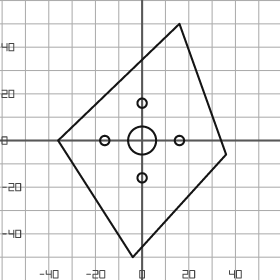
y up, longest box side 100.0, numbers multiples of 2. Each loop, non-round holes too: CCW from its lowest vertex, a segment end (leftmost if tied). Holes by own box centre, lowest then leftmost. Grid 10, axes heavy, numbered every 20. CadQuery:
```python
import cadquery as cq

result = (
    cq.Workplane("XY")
    .moveTo(-4.0, -50.0)
    .lineTo(36.0, -6.0)
    .lineTo(16.0, 50.0)
    .lineTo(-36.0, 0.0)
    .close()
    .moveTo(0.0, -16.0)
    .circle(2.0)
    .moveTo(-16.0, 0.0)
    .circle(2.0)
    .moveTo(0.0, 0.0)
    .circle(6.0)
    .moveTo(16.0, 0.0)
    .circle(2.0)
    .moveTo(0.0, 16.0)
    .circle(2.0)
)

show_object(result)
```